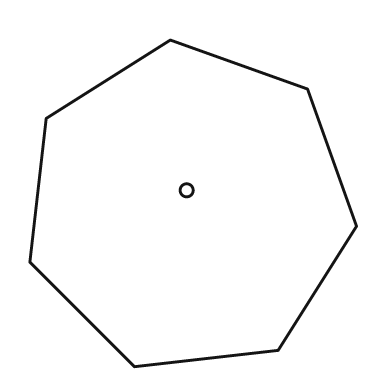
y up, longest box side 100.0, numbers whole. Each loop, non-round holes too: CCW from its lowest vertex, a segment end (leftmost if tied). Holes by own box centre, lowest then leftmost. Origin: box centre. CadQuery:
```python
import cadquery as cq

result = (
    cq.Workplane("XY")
    .moveTo(-18.0, -50.0)
    .lineTo(26.0, -45.0)
    .lineTo(50.0, -7.0)
    .lineTo(35.0, 35.0)
    .lineTo(-7.0, 50.0)
    .lineTo(-45.0, 26.0)
    .lineTo(-50.0, -18.0)
    .close()
    .moveTo(-2.0, 4.0)
    .circle(2.0)
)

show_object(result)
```